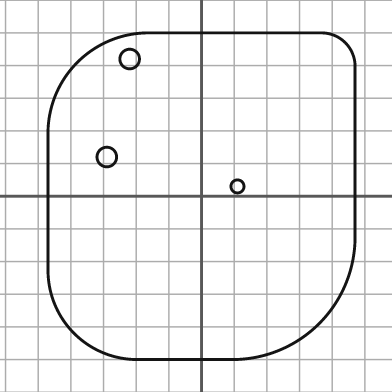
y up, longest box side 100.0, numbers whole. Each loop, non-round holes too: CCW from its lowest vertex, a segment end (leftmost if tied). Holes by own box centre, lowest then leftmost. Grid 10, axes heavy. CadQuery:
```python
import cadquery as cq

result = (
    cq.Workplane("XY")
    .moveTo(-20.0, -50.0)
    .lineTo(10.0, -50.0)
    .threePointArc((36.0, -39.0), (47.0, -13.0))
    .lineTo(47.0, 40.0)
    .threePointArc((44.0, 47.0), (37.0, 50.0))
    .lineTo(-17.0, 50.0)
    .threePointArc((-38.0, 41.0), (-47.0, 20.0))
    .lineTo(-47.0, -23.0)
    .threePointArc((-39.0, -42.0), (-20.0, -50.0))
    .close()
    .moveTo(11.0, 3.0)
    .circle(2.0)
    .moveTo(-29.0, 12.0)
    .circle(3.0)
    .moveTo(-22.0, 42.0)
    .circle(3.0)
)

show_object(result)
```